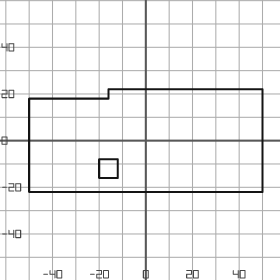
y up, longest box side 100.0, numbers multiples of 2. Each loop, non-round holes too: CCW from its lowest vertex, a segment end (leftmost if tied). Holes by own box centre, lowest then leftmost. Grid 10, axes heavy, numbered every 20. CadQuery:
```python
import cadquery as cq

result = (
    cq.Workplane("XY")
    .moveTo(-50.0, -22.0)
    .lineTo(50.0, -22.0)
    .lineTo(50.0, 22.0)
    .lineTo(-16.0, 22.0)
    .lineTo(-16.0, 18.0)
    .lineTo(-50.0, 18.0)
    .close()
    .moveTo(-20.0, -16.0)
    .lineTo(-12.0, -16.0)
    .lineTo(-12.0, -8.0)
    .lineTo(-20.0, -8.0)
    .close()
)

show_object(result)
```